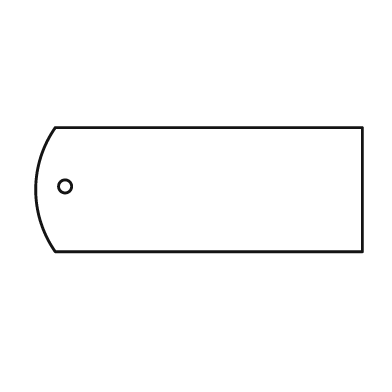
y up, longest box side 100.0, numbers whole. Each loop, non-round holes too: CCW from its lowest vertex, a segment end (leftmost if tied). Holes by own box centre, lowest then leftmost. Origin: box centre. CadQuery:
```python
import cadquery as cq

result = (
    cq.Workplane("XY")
    .moveTo(-44.0, -19.0)
    .lineTo(50.0, -19.0)
    .lineTo(50.0, 19.0)
    .lineTo(-44.0, 19.0)
    .threePointArc((-50.0, 0.0), (-44.0, -19.0))
    .close()
    .moveTo(-41.0, 1.0)
    .circle(2.0)
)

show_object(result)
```